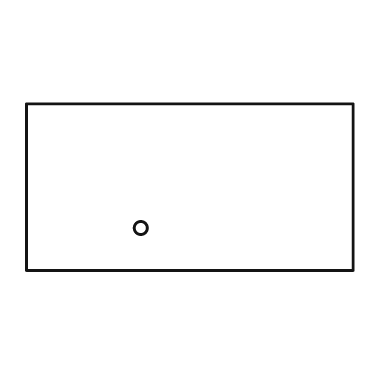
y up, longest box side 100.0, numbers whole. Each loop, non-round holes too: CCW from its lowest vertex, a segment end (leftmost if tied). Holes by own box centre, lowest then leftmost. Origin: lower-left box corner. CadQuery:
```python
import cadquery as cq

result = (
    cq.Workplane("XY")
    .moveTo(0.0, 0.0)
    .lineTo(100.0, 0.0)
    .lineTo(100.0, 51.0)
    .lineTo(0.0, 51.0)
    .close()
    .moveTo(35.0, 13.0)
    .circle(2.0)
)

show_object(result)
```